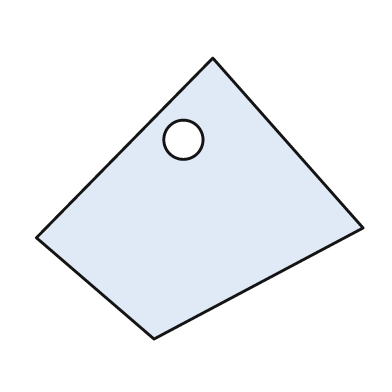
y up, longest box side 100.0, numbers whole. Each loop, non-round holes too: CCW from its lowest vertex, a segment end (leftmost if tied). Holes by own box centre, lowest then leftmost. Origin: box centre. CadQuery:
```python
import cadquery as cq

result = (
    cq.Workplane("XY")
    .moveTo(-14.0, -43.0)
    .lineTo(50.0, -9.0)
    .lineTo(4.0, 43.0)
    .lineTo(-50.0, -12.0)
    .close()
    .moveTo(-5.0, 18.0)
    .circle(6.0)
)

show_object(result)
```